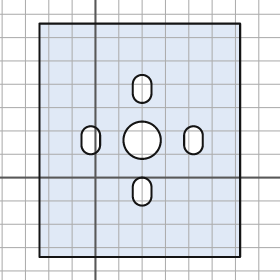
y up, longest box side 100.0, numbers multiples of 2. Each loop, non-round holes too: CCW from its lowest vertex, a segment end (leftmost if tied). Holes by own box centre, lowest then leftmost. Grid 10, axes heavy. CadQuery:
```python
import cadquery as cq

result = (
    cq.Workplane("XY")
    .moveTo(-24.0, -34.0)
    .lineTo(62.0, -34.0)
    .lineTo(62.0, 66.0)
    .lineTo(-24.0, 66.0)
    .close()
    .moveTo(16.0, -8.0)
    .threePointArc((20.0, -12.0), (24.0, -8.0))
    .lineTo(24.0, -4.0)
    .threePointArc((20.0, 0.0), (16.0, -4.0))
    .close()
    .moveTo(-6.0, 14.0)
    .threePointArc((-2.0, 10.0), (2.0, 14.0))
    .lineTo(2.0, 18.0)
    .threePointArc((-2.0, 22.0), (-6.0, 18.0))
    .close()
    .moveTo(20.0, 16.0)
    .circle(8.0)
    .moveTo(38.0, 14.0)
    .threePointArc((42.0, 10.0), (46.0, 14.0))
    .lineTo(46.0, 18.0)
    .threePointArc((42.0, 22.0), (38.0, 18.0))
    .close()
    .moveTo(16.0, 36.0)
    .threePointArc((20.0, 32.0), (24.0, 36.0))
    .lineTo(24.0, 40.0)
    .threePointArc((20.0, 44.0), (16.0, 40.0))
    .close()
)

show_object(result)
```